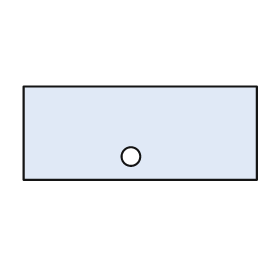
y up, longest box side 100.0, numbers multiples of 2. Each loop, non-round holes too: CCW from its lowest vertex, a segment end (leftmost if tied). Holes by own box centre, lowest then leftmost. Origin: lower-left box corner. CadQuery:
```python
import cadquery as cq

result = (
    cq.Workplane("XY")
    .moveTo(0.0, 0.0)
    .lineTo(100.0, 0.0)
    .lineTo(100.0, 40.0)
    .lineTo(0.0, 40.0)
    .close()
    .moveTo(46.0, 10.0)
    .circle(4.0)
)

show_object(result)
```